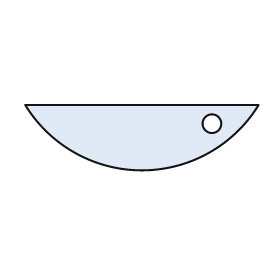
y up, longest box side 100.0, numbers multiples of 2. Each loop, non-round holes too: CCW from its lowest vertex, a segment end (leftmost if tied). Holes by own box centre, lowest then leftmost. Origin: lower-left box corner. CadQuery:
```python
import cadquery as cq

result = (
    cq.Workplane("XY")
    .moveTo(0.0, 28.0)
    .threePointArc((50.0, 0.0), (100.0, 28.0))
    .close()
    .moveTo(80.0, 20.0)
    .circle(4.0)
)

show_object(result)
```